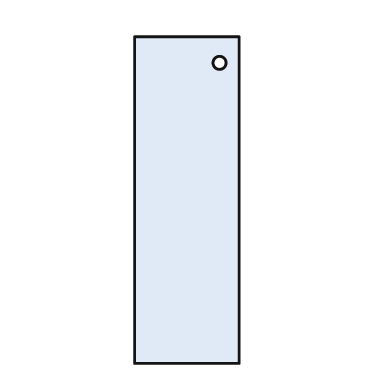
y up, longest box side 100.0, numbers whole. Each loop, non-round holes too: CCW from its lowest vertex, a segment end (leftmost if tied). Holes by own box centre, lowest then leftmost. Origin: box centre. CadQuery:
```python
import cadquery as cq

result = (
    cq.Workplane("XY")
    .moveTo(-16.0, -50.0)
    .lineTo(16.0, -50.0)
    .lineTo(16.0, 50.0)
    .lineTo(-16.0, 50.0)
    .close()
    .moveTo(10.0, 42.0)
    .circle(2.0)
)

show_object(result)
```